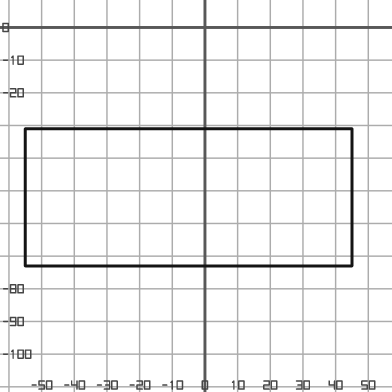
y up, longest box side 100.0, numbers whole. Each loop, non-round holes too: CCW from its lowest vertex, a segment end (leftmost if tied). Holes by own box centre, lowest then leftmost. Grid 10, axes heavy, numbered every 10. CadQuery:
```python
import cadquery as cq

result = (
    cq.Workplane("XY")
    .moveTo(-55.0, -73.0)
    .lineTo(45.0, -73.0)
    .lineTo(45.0, -31.0)
    .lineTo(-55.0, -31.0)
    .close()
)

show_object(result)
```